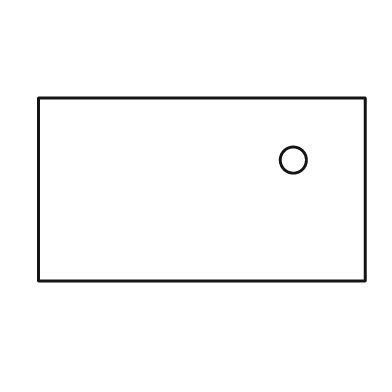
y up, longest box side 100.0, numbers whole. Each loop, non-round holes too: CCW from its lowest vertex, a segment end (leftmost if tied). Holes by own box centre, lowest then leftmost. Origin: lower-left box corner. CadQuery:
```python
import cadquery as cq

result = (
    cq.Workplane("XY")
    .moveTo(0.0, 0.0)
    .lineTo(100.0, 0.0)
    .lineTo(100.0, 56.0)
    .lineTo(0.0, 56.0)
    .close()
    .moveTo(78.0, 37.0)
    .circle(4.0)
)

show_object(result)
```